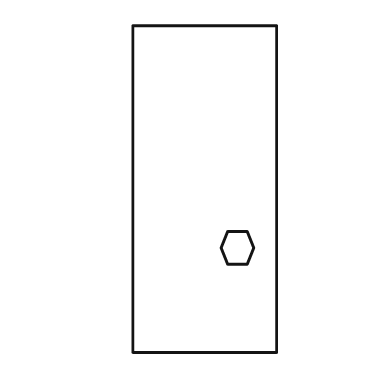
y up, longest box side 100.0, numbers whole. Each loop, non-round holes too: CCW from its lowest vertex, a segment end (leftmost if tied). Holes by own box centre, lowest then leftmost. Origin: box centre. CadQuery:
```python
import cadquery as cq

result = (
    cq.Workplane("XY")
    .moveTo(-22.0, -50.0)
    .lineTo(22.0, -50.0)
    .lineTo(22.0, 50.0)
    .lineTo(-22.0, 50.0)
    .close()
    .moveTo(7.0, -23.0)
    .lineTo(13.0, -23.0)
    .lineTo(15.0, -18.0)
    .lineTo(13.0, -13.0)
    .lineTo(7.0, -13.0)
    .lineTo(5.0, -18.0)
    .close()
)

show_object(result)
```